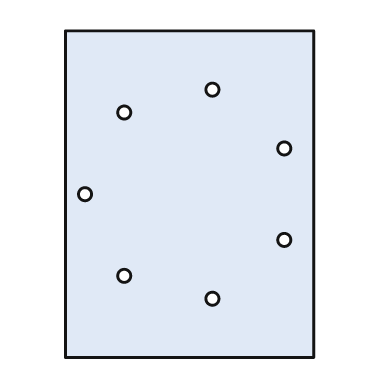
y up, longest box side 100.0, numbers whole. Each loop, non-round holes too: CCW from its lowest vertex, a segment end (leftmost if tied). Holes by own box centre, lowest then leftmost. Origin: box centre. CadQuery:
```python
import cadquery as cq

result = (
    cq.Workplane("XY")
    .moveTo(-38.0, -50.0)
    .lineTo(38.0, -50.0)
    .lineTo(38.0, 50.0)
    .lineTo(-38.0, 50.0)
    .close()
    .moveTo(7.0, -32.0)
    .circle(2.0)
    .moveTo(-20.0, -25.0)
    .circle(2.0)
    .moveTo(29.0, -14.0)
    .circle(2.0)
    .moveTo(-32.0, 0.0)
    .circle(2.0)
    .moveTo(29.0, 14.0)
    .circle(2.0)
    .moveTo(-20.0, 25.0)
    .circle(2.0)
    .moveTo(7.0, 32.0)
    .circle(2.0)
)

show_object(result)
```